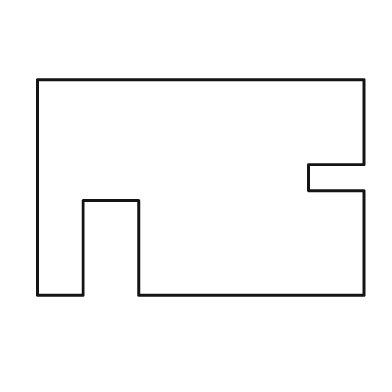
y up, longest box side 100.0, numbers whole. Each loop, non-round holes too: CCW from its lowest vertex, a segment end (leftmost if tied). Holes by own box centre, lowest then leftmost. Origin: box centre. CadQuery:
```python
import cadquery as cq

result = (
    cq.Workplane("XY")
    .moveTo(-50.0, -33.0)
    .lineTo(-36.0, -33.0)
    .lineTo(-36.0, -4.0)
    .lineTo(-19.0, -4.0)
    .lineTo(-19.0, -33.0)
    .lineTo(50.0, -33.0)
    .lineTo(50.0, -1.0)
    .lineTo(33.0, -1.0)
    .lineTo(33.0, 7.0)
    .lineTo(50.0, 7.0)
    .lineTo(50.0, 33.0)
    .lineTo(-50.0, 33.0)
    .close()
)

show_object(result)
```